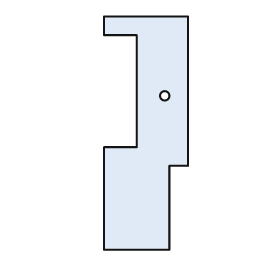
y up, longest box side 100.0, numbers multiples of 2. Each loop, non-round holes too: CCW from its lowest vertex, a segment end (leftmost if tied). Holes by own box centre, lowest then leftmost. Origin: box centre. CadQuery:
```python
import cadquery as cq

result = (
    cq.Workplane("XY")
    .moveTo(-18.0, -50.0)
    .lineTo(10.0, -50.0)
    .lineTo(10.0, -14.0)
    .lineTo(18.0, -14.0)
    .lineTo(18.0, 50.0)
    .lineTo(-18.0, 50.0)
    .lineTo(-18.0, 42.0)
    .lineTo(-4.0, 42.0)
    .lineTo(-4.0, -6.0)
    .lineTo(-18.0, -6.0)
    .close()
    .moveTo(8.0, 16.0)
    .circle(2.0)
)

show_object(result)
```